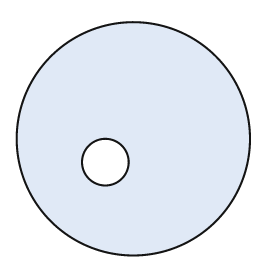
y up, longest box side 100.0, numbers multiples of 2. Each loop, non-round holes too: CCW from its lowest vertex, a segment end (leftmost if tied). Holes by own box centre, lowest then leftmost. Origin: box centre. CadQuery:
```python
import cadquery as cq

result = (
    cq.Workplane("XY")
    .moveTo(0.0, 0.0)
    .circle(50.0)
    .moveTo(-12.0, -10.0)
    .circle(10.0)
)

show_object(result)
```